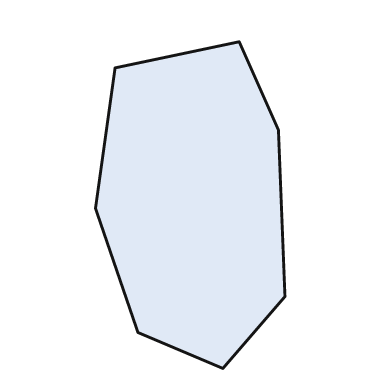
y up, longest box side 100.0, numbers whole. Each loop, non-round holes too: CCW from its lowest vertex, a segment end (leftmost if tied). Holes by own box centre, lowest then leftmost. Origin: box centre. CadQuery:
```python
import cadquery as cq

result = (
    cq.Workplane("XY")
    .moveTo(10.0, -50.0)
    .lineTo(29.0, -28.0)
    .lineTo(27.0, 23.0)
    .lineTo(15.0, 50.0)
    .lineTo(-23.0, 42.0)
    .lineTo(-29.0, -1.0)
    .lineTo(-16.0, -39.0)
    .close()
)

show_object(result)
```